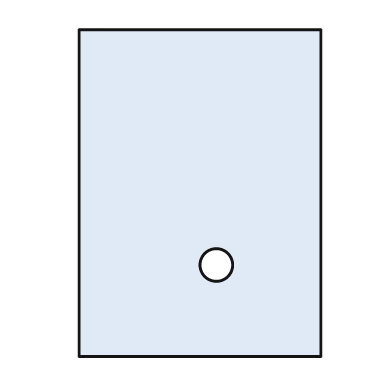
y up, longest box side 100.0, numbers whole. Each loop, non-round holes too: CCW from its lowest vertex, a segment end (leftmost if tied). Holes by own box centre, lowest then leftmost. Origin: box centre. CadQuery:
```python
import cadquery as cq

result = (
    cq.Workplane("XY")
    .moveTo(-37.0, -50.0)
    .lineTo(37.0, -50.0)
    .lineTo(37.0, 50.0)
    .lineTo(-37.0, 50.0)
    .close()
    .moveTo(5.0, -22.0)
    .circle(5.0)
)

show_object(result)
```